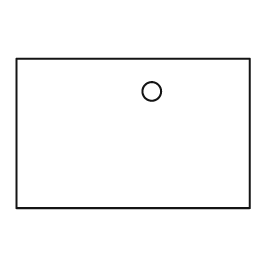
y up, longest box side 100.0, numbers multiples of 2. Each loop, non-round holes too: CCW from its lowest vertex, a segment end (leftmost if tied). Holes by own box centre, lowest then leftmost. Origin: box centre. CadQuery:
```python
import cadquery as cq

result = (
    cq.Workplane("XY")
    .moveTo(-50.0, -32.0)
    .lineTo(50.0, -32.0)
    .lineTo(50.0, 32.0)
    .lineTo(-50.0, 32.0)
    .close()
    .moveTo(8.0, 18.0)
    .circle(4.0)
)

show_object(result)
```